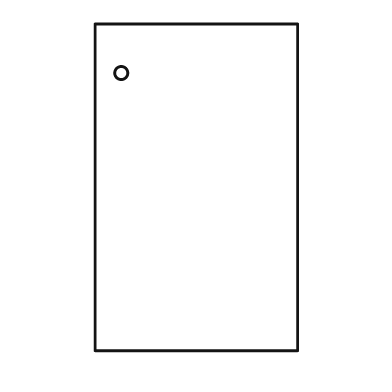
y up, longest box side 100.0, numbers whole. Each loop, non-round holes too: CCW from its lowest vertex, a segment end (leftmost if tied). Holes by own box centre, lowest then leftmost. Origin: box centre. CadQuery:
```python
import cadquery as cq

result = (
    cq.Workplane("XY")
    .moveTo(-31.0, -50.0)
    .lineTo(31.0, -50.0)
    .lineTo(31.0, 50.0)
    .lineTo(-31.0, 50.0)
    .close()
    .moveTo(-23.0, 35.0)
    .circle(2.0)
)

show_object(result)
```